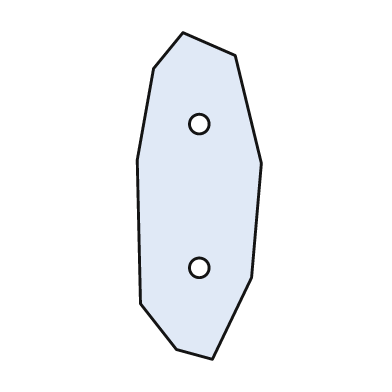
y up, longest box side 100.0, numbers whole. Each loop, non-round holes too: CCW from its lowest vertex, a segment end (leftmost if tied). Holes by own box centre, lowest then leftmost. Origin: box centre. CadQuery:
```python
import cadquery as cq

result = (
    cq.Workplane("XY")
    .moveTo(4.0, -50.0)
    .lineTo(16.0, -25.0)
    .lineTo(19.0, 10.0)
    .lineTo(11.0, 43.0)
    .lineTo(-5.0, 50.0)
    .lineTo(-14.0, 39.0)
    .lineTo(-19.0, 11.0)
    .lineTo(-18.0, -33.0)
    .lineTo(-7.0, -47.0)
    .close()
    .moveTo(0.0, -22.0)
    .circle(3.0)
    .moveTo(0.0, 22.0)
    .circle(3.0)
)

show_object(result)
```